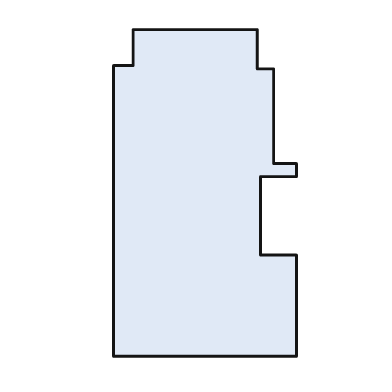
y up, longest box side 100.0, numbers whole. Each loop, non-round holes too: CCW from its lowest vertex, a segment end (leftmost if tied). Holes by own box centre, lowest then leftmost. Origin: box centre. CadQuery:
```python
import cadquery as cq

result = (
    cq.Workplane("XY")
    .moveTo(-28.0, -50.0)
    .lineTo(28.0, -50.0)
    .lineTo(28.0, -19.0)
    .lineTo(17.0, -19.0)
    .lineTo(17.0, 5.0)
    .lineTo(28.0, 5.0)
    .lineTo(28.0, 9.0)
    .lineTo(21.0, 9.0)
    .lineTo(21.0, 38.0)
    .lineTo(16.0, 38.0)
    .lineTo(16.0, 50.0)
    .lineTo(-22.0, 50.0)
    .lineTo(-22.0, 39.0)
    .lineTo(-28.0, 39.0)
    .close()
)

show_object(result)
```